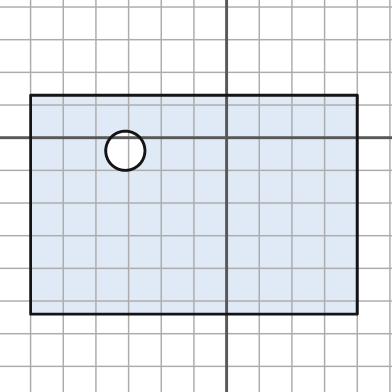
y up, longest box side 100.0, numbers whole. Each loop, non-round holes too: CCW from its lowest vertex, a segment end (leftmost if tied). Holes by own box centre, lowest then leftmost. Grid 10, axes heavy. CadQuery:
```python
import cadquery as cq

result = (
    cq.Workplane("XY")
    .moveTo(-60.0, -54.0)
    .lineTo(40.0, -54.0)
    .lineTo(40.0, 13.0)
    .lineTo(-60.0, 13.0)
    .close()
    .moveTo(-31.0, -4.0)
    .circle(6.0)
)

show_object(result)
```